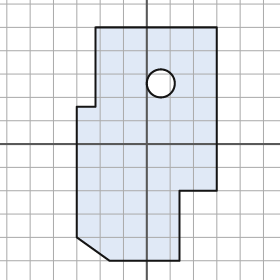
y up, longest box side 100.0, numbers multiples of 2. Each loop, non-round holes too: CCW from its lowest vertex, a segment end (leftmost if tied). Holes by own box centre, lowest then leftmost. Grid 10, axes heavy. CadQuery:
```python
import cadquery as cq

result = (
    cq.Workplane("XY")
    .moveTo(-16.0, -50.0)
    .lineTo(14.0, -50.0)
    .lineTo(14.0, -20.0)
    .lineTo(30.0, -20.0)
    .lineTo(30.0, 50.0)
    .lineTo(-22.0, 50.0)
    .lineTo(-22.0, 16.0)
    .lineTo(-30.0, 16.0)
    .lineTo(-30.0, -40.0)
    .close()
    .moveTo(6.0, 26.0)
    .circle(6.0)
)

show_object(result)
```